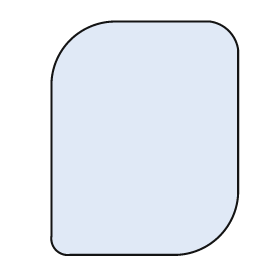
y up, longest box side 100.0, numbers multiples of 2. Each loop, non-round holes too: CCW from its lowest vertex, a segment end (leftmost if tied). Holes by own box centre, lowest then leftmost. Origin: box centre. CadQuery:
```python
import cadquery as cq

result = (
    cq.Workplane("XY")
    .moveTo(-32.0, -50.0)
    .lineTo(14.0, -50.0)
    .threePointArc((32.0, -42.0), (40.0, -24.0))
    .lineTo(40.0, 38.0)
    .threePointArc((36.0, 46.0), (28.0, 50.0))
    .lineTo(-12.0, 50.0)
    .threePointArc((-32.0, 42.0), (-40.0, 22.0))
    .lineTo(-40.0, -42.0)
    .threePointArc((-38.0, -48.0), (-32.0, -50.0))
    .close()
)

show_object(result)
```